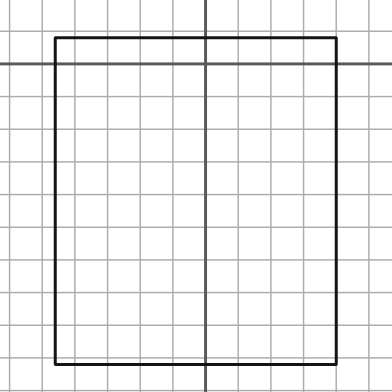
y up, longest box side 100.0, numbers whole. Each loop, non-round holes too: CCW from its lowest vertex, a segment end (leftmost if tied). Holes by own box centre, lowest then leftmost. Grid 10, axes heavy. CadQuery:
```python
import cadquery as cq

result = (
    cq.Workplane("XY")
    .moveTo(-46.0, -92.0)
    .lineTo(40.0, -92.0)
    .lineTo(40.0, 8.0)
    .lineTo(-46.0, 8.0)
    .close()
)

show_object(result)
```